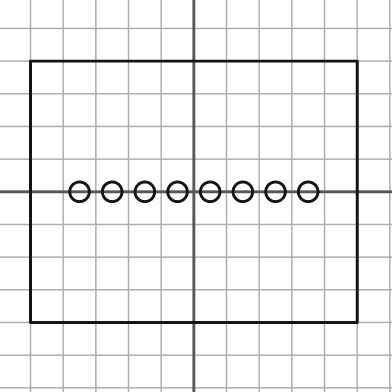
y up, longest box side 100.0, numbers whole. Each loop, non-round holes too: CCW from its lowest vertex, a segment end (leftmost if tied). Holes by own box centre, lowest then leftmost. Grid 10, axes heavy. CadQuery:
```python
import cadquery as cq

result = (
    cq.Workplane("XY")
    .moveTo(-50.0, -40.0)
    .lineTo(50.0, -40.0)
    .lineTo(50.0, 40.0)
    .lineTo(-50.0, 40.0)
    .close()
    .moveTo(-35.0, 0.0)
    .circle(3.0)
    .moveTo(-25.0, 0.0)
    .circle(3.0)
    .moveTo(-15.0, 0.0)
    .circle(3.0)
    .moveTo(-5.0, 0.0)
    .circle(3.0)
    .moveTo(5.0, 0.0)
    .circle(3.0)
    .moveTo(15.0, 0.0)
    .circle(3.0)
    .moveTo(25.0, 0.0)
    .circle(3.0)
    .moveTo(35.0, 0.0)
    .circle(3.0)
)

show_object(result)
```